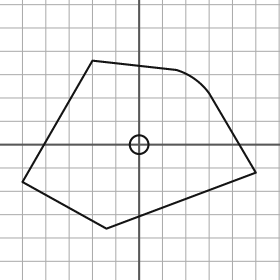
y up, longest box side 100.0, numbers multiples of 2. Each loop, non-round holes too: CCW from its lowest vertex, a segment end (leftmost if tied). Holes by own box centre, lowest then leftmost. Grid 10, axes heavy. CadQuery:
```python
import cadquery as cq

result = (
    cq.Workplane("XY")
    .moveTo(-14.0, -36.0)
    .lineTo(50.0, -12.0)
    .lineTo(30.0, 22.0)
    .threePointArc((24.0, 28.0), (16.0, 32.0))
    .lineTo(-20.0, 36.0)
    .lineTo(-50.0, -16.0)
    .close()
    .moveTo(0.0, 0.0)
    .circle(4.0)
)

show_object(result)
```